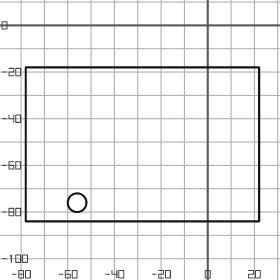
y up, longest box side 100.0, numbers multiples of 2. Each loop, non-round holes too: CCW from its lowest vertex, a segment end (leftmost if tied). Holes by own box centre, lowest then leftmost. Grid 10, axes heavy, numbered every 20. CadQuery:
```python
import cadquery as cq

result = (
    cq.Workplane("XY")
    .moveTo(-78.0, -84.0)
    .lineTo(22.0, -84.0)
    .lineTo(22.0, -18.0)
    .lineTo(-78.0, -18.0)
    .close()
    .moveTo(-56.0, -76.0)
    .circle(4.0)
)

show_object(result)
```